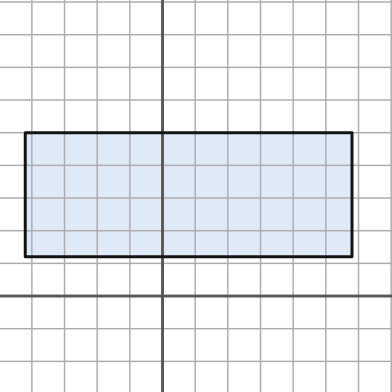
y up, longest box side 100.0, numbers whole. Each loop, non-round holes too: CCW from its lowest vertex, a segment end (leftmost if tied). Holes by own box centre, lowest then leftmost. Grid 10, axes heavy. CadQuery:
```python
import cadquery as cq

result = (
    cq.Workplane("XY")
    .moveTo(-42.0, 12.0)
    .lineTo(58.0, 12.0)
    .lineTo(58.0, 50.0)
    .lineTo(-42.0, 50.0)
    .close()
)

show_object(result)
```